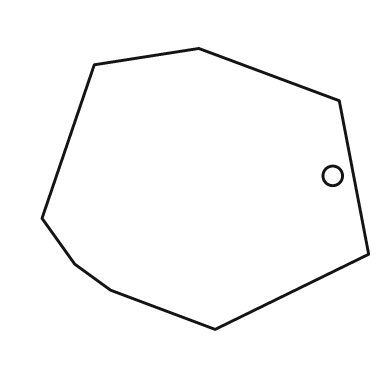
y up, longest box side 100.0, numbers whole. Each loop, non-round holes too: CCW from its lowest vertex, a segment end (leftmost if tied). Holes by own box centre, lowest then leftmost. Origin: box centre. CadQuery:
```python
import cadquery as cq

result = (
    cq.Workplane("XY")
    .moveTo(3.0, -43.0)
    .lineTo(50.0, -20.0)
    .lineTo(41.0, 27.0)
    .lineTo(-2.0, 43.0)
    .lineTo(-34.0, 38.0)
    .lineTo(-50.0, -9.0)
    .lineTo(-40.0, -23.0)
    .lineTo(-29.0, -31.0)
    .close()
    .moveTo(39.0, 4.0)
    .circle(3.0)
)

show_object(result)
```